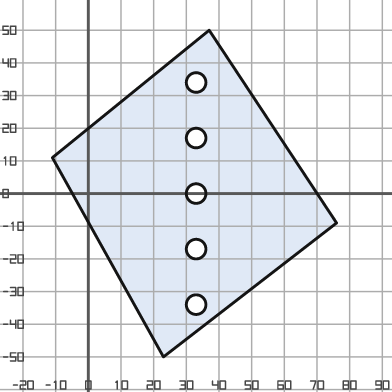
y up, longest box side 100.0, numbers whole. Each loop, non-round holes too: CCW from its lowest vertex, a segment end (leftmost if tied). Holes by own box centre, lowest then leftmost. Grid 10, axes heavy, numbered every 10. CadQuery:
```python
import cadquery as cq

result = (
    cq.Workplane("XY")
    .moveTo(23.0, -50.0)
    .lineTo(76.0, -9.0)
    .lineTo(37.0, 50.0)
    .lineTo(-11.0, 11.0)
    .close()
    .moveTo(33.0, -34.0)
    .circle(3.0)
    .moveTo(33.0, -17.0)
    .circle(3.0)
    .moveTo(33.0, 0.0)
    .circle(3.0)
    .moveTo(33.0, 17.0)
    .circle(3.0)
    .moveTo(33.0, 34.0)
    .circle(3.0)
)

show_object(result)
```